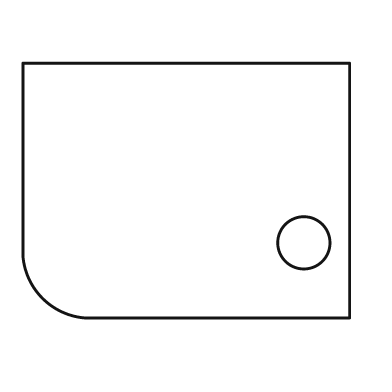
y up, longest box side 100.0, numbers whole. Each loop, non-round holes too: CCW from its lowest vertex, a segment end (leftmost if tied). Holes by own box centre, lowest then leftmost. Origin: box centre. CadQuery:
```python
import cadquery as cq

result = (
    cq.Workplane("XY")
    .moveTo(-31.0, -39.0)
    .lineTo(50.0, -39.0)
    .lineTo(50.0, 39.0)
    .lineTo(-50.0, 39.0)
    .lineTo(-50.0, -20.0)
    .threePointArc((-44.0, -33.0), (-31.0, -39.0))
    .close()
    .moveTo(36.0, -16.0)
    .circle(8.0)
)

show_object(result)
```